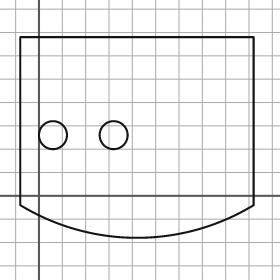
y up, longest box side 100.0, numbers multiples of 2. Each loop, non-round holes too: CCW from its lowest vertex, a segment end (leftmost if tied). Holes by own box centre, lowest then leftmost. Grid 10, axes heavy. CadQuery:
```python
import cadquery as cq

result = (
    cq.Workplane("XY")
    .moveTo(-8.0, -4.0)
    .threePointArc((42.0, -18.0), (92.0, -4.0))
    .lineTo(92.0, 68.0)
    .lineTo(-8.0, 68.0)
    .close()
    .moveTo(6.0, 26.0)
    .circle(6.0)
    .moveTo(32.0, 26.0)
    .circle(6.0)
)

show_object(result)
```